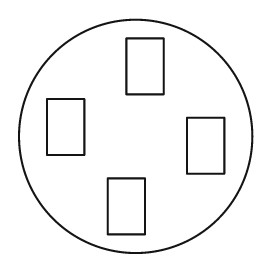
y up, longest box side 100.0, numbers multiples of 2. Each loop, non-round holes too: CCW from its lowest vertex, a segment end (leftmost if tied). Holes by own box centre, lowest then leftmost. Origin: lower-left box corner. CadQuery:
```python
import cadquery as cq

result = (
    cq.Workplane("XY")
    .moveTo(50.0, 50.0)
    .circle(50.0)
    .moveTo(38.0, 8.0)
    .lineTo(54.0, 8.0)
    .lineTo(54.0, 32.0)
    .lineTo(38.0, 32.0)
    .close()
    .moveTo(72.0, 34.0)
    .lineTo(88.0, 34.0)
    .lineTo(88.0, 58.0)
    .lineTo(72.0, 58.0)
    .close()
    .moveTo(12.0, 42.0)
    .lineTo(28.0, 42.0)
    .lineTo(28.0, 66.0)
    .lineTo(12.0, 66.0)
    .close()
    .moveTo(46.0, 68.0)
    .lineTo(62.0, 68.0)
    .lineTo(62.0, 92.0)
    .lineTo(46.0, 92.0)
    .close()
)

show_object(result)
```